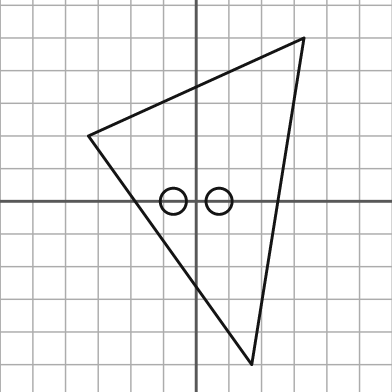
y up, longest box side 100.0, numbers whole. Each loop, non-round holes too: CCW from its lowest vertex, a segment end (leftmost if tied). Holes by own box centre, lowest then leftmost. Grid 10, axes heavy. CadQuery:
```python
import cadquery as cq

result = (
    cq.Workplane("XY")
    .moveTo(17.0, -50.0)
    .lineTo(33.0, 50.0)
    .lineTo(-33.0, 20.0)
    .close()
    .moveTo(-7.0, 0.0)
    .circle(4.0)
    .moveTo(7.0, 0.0)
    .circle(4.0)
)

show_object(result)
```